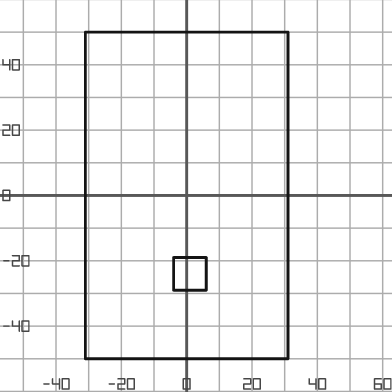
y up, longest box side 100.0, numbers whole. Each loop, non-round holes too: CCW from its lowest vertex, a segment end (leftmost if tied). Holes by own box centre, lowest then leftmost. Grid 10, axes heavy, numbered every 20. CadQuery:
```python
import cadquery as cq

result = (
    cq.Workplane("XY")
    .moveTo(-31.0, -50.0)
    .lineTo(31.0, -50.0)
    .lineTo(31.0, 50.0)
    .lineTo(-31.0, 50.0)
    .close()
    .moveTo(-4.0, -29.0)
    .lineTo(6.0, -29.0)
    .lineTo(6.0, -19.0)
    .lineTo(-4.0, -19.0)
    .close()
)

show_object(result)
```